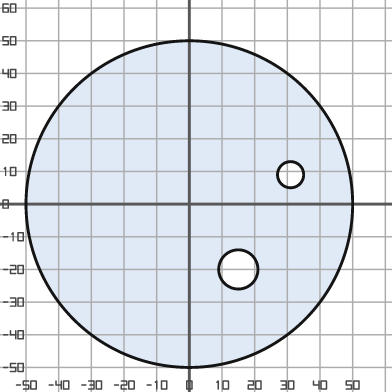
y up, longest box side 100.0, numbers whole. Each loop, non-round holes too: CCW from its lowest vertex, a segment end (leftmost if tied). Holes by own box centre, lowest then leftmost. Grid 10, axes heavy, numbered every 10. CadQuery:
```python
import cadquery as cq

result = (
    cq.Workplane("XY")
    .moveTo(0.0, 0.0)
    .circle(50.0)
    .moveTo(15.0, -20.0)
    .circle(6.0)
    .moveTo(31.0, 9.0)
    .circle(4.0)
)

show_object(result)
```